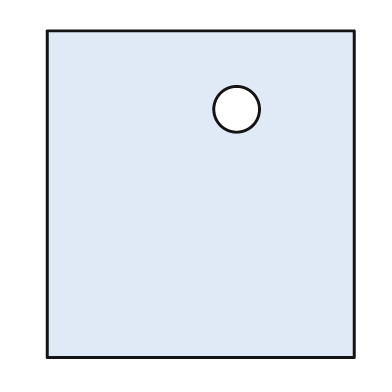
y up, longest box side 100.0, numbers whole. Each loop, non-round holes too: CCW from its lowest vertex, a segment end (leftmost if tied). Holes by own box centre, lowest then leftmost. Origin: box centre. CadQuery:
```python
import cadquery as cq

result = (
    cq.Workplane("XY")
    .moveTo(-47.0, -50.0)
    .lineTo(47.0, -50.0)
    .lineTo(47.0, 50.0)
    .lineTo(-47.0, 50.0)
    .close()
    .moveTo(11.0, 26.0)
    .circle(7.0)
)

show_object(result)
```